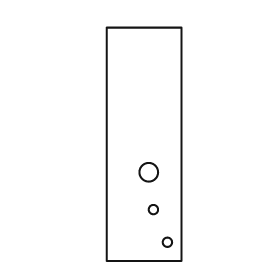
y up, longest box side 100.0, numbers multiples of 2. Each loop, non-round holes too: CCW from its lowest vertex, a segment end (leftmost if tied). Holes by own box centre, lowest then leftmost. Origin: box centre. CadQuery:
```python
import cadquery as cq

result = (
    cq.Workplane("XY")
    .moveTo(-16.0, -50.0)
    .lineTo(16.0, -50.0)
    .lineTo(16.0, 50.0)
    .lineTo(-16.0, 50.0)
    .close()
    .moveTo(10.0, -42.0)
    .circle(2.0)
    .moveTo(4.0, -28.0)
    .circle(2.0)
    .moveTo(2.0, -12.0)
    .circle(4.0)
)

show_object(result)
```